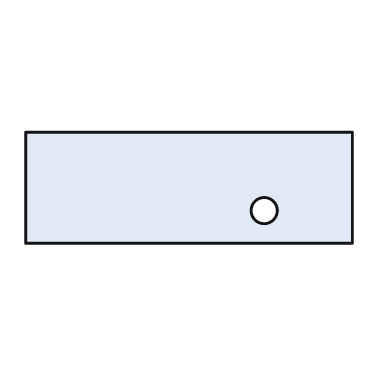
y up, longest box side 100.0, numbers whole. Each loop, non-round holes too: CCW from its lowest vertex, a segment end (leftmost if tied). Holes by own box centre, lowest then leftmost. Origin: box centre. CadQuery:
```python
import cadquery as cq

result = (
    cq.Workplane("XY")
    .moveTo(-50.0, -17.0)
    .lineTo(50.0, -17.0)
    .lineTo(50.0, 17.0)
    .lineTo(-50.0, 17.0)
    .close()
    .moveTo(23.0, -7.0)
    .circle(4.0)
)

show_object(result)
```